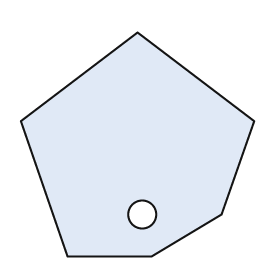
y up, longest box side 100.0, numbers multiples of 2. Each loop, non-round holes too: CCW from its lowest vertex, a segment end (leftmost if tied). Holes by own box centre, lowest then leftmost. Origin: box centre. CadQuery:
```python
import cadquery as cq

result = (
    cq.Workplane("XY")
    .moveTo(-30.0, -48.0)
    .lineTo(6.0, -48.0)
    .lineTo(36.0, -30.0)
    .lineTo(50.0, 10.0)
    .lineTo(0.0, 48.0)
    .lineTo(-50.0, 10.0)
    .close()
    .moveTo(2.0, -30.0)
    .circle(6.0)
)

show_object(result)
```